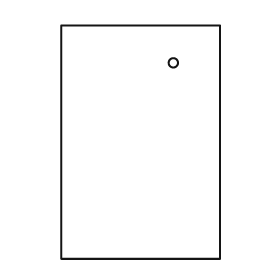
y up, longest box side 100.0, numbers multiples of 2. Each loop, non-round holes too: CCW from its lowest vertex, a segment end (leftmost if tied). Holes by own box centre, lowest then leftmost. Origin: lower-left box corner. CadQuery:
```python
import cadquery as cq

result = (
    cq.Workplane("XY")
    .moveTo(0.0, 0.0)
    .lineTo(68.0, 0.0)
    .lineTo(68.0, 100.0)
    .lineTo(0.0, 100.0)
    .close()
    .moveTo(48.0, 84.0)
    .circle(2.0)
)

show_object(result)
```